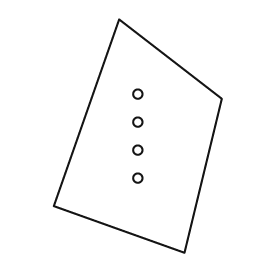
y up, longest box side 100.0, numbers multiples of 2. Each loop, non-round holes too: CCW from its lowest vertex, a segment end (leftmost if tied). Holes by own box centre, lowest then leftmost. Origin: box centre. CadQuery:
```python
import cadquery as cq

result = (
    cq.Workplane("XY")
    .moveTo(20.0, -50.0)
    .lineTo(36.0, 16.0)
    .lineTo(-8.0, 50.0)
    .lineTo(-36.0, -30.0)
    .close()
    .moveTo(0.0, -18.0)
    .circle(2.0)
    .moveTo(0.0, -6.0)
    .circle(2.0)
    .moveTo(0.0, 6.0)
    .circle(2.0)
    .moveTo(0.0, 18.0)
    .circle(2.0)
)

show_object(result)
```